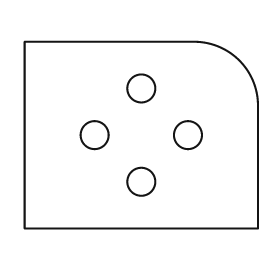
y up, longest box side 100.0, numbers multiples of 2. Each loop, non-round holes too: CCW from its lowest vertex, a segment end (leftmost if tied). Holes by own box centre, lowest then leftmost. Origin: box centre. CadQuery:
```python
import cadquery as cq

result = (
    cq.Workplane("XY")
    .moveTo(-50.0, -40.0)
    .lineTo(50.0, -40.0)
    .lineTo(50.0, 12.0)
    .threePointArc((42.0, 32.0), (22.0, 40.0))
    .lineTo(-50.0, 40.0)
    .close()
    .moveTo(0.0, -20.0)
    .circle(6.0)
    .moveTo(-20.0, 0.0)
    .circle(6.0)
    .moveTo(20.0, 0.0)
    .circle(6.0)
    .moveTo(0.0, 20.0)
    .circle(6.0)
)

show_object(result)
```